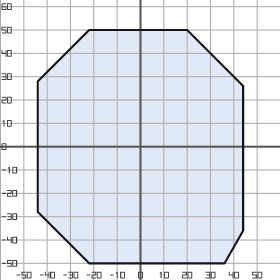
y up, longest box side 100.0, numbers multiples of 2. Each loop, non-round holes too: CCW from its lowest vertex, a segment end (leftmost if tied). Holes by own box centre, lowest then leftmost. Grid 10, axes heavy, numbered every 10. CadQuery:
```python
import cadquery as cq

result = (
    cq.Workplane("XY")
    .moveTo(-22.0, -50.0)
    .lineTo(36.0, -50.0)
    .lineTo(44.0, -36.0)
    .lineTo(44.0, 26.0)
    .lineTo(20.0, 50.0)
    .lineTo(-22.0, 50.0)
    .lineTo(-44.0, 28.0)
    .lineTo(-44.0, -28.0)
    .close()
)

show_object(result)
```